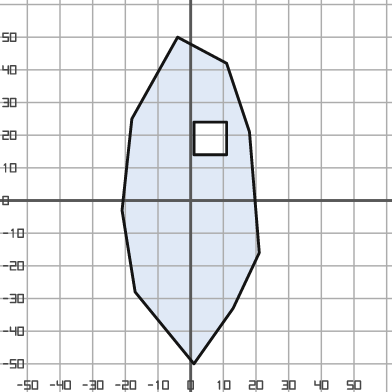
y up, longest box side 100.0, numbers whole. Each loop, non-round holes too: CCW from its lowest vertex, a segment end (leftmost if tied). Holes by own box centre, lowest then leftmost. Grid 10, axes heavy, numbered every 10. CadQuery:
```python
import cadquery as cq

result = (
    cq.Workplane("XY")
    .moveTo(1.0, -50.0)
    .lineTo(13.0, -33.0)
    .lineTo(21.0, -16.0)
    .lineTo(18.0, 21.0)
    .lineTo(11.0, 42.0)
    .lineTo(-4.0, 50.0)
    .lineTo(-18.0, 25.0)
    .lineTo(-21.0, -3.0)
    .lineTo(-17.0, -28.0)
    .close()
    .moveTo(1.0, 14.0)
    .lineTo(11.0, 14.0)
    .lineTo(11.0, 24.0)
    .lineTo(1.0, 24.0)
    .close()
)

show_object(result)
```